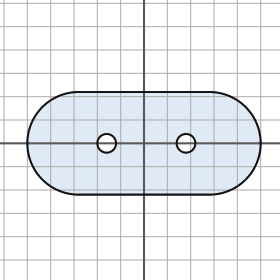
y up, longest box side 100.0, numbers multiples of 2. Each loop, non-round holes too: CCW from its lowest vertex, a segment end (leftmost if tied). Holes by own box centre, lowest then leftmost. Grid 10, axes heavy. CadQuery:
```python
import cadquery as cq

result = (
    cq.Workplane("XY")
    .moveTo(-28.0, -22.0)
    .lineTo(28.0, -22.0)
    .threePointArc((50.0, 0.0), (28.0, 22.0))
    .lineTo(-28.0, 22.0)
    .threePointArc((-50.0, 0.0), (-28.0, -22.0))
    .close()
    .moveTo(-16.0, 0.0)
    .circle(4.0)
    .moveTo(18.0, 0.0)
    .circle(4.0)
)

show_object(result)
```